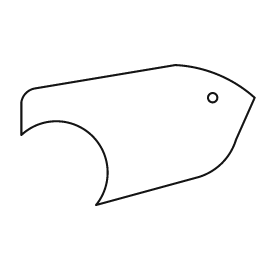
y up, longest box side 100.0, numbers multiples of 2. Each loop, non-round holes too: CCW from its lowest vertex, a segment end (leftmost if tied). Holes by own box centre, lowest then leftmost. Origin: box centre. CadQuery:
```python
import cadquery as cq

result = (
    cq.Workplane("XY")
    .moveTo(-18.0, -30.0)
    .lineTo(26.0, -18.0)
    .threePointArc((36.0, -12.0), (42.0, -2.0))
    .lineTo(50.0, 16.0)
    .threePointArc((34.0, 26.0), (16.0, 30.0))
    .lineTo(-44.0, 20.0)
    .threePointArc((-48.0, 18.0), (-50.0, 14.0))
    .lineTo(-50.0, 0.0)
    .threePointArc((-20.0, 0.0), (-18.0, -30.0))
    .close()
    .moveTo(32.0, 16.0)
    .circle(2.0)
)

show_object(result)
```